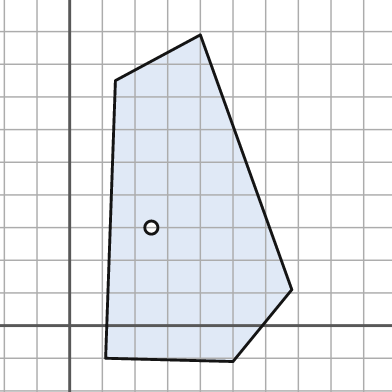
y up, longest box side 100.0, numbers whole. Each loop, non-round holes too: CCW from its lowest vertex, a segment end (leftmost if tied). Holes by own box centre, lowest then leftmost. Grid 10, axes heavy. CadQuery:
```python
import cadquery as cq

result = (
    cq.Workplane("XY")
    .moveTo(50.0, -11.0)
    .lineTo(68.0, 11.0)
    .lineTo(40.0, 89.0)
    .lineTo(14.0, 75.0)
    .lineTo(11.0, -10.0)
    .close()
    .moveTo(25.0, 30.0)
    .circle(2.0)
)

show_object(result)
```